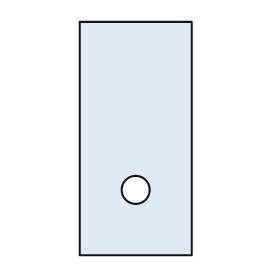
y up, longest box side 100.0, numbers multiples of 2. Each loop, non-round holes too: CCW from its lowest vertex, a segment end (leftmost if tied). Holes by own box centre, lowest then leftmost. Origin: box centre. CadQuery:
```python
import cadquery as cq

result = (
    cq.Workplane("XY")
    .moveTo(-24.0, -50.0)
    .lineTo(24.0, -50.0)
    .lineTo(24.0, 50.0)
    .lineTo(-24.0, 50.0)
    .close()
    .moveTo(0.0, -22.0)
    .circle(6.0)
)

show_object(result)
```